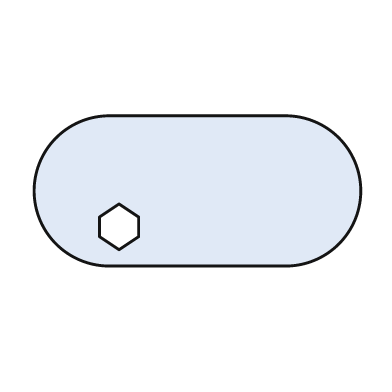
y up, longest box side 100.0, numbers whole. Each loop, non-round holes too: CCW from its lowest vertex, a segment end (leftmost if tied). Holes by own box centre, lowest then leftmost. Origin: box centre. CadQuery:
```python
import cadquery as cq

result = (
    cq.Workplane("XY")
    .moveTo(-27.0, -23.0)
    .lineTo(27.0, -23.0)
    .threePointArc((50.0, 0.0), (27.0, 23.0))
    .lineTo(-27.0, 23.0)
    .threePointArc((-50.0, 0.0), (-27.0, -23.0))
    .close()
    .moveTo(-24.0, -18.0)
    .lineTo(-18.0, -14.0)
    .lineTo(-18.0, -8.0)
    .lineTo(-24.0, -4.0)
    .lineTo(-30.0, -8.0)
    .lineTo(-30.0, -14.0)
    .close()
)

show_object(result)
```